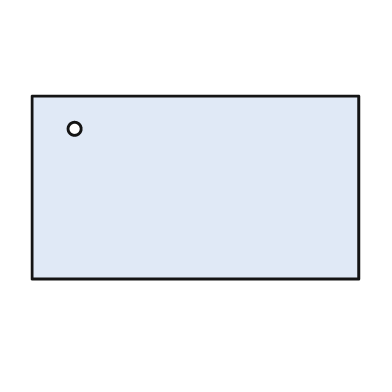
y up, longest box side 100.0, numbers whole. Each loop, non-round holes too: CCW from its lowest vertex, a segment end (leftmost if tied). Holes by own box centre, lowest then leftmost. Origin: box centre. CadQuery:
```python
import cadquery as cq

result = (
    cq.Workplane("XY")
    .moveTo(-50.0, -28.0)
    .lineTo(50.0, -28.0)
    .lineTo(50.0, 28.0)
    .lineTo(-50.0, 28.0)
    .close()
    .moveTo(-37.0, 18.0)
    .circle(2.0)
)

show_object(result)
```